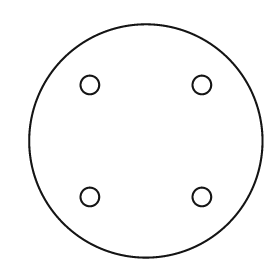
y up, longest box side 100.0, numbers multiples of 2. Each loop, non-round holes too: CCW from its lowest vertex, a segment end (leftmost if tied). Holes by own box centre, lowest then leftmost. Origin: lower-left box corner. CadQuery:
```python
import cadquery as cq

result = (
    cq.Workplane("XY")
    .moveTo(50.0, 50.0)
    .circle(50.0)
    .moveTo(26.0, 26.0)
    .circle(4.0)
    .moveTo(74.0, 26.0)
    .circle(4.0)
    .moveTo(26.0, 74.0)
    .circle(4.0)
    .moveTo(74.0, 74.0)
    .circle(4.0)
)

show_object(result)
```